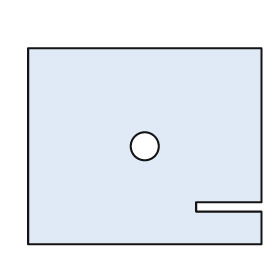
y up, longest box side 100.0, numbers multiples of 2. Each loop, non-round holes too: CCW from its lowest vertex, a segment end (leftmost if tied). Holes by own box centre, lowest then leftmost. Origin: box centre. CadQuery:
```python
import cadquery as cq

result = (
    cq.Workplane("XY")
    .moveTo(-50.0, -42.0)
    .lineTo(50.0, -42.0)
    .lineTo(50.0, -28.0)
    .lineTo(22.0, -28.0)
    .lineTo(22.0, -24.0)
    .lineTo(50.0, -24.0)
    .lineTo(50.0, 42.0)
    .lineTo(-50.0, 42.0)
    .close()
    .moveTo(0.0, 0.0)
    .circle(6.0)
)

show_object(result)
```